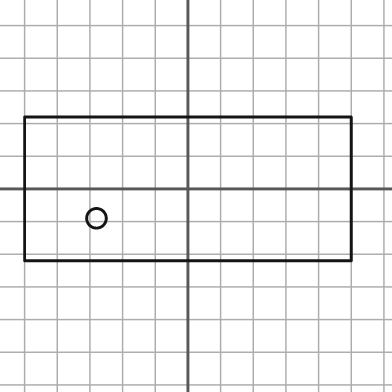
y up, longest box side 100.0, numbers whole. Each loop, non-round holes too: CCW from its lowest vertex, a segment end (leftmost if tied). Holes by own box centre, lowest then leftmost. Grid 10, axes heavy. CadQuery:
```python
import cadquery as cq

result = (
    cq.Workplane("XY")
    .moveTo(-50.0, -22.0)
    .lineTo(50.0, -22.0)
    .lineTo(50.0, 22.0)
    .lineTo(-50.0, 22.0)
    .close()
    .moveTo(-28.0, -9.0)
    .circle(3.0)
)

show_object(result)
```